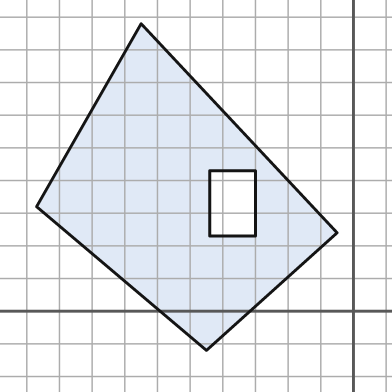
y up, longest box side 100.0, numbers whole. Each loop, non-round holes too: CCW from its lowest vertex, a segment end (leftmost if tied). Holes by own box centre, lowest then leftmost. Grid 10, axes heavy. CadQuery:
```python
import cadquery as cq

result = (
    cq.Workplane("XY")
    .moveTo(-45.0, -12.0)
    .lineTo(-5.0, 24.0)
    .lineTo(-65.0, 88.0)
    .lineTo(-97.0, 32.0)
    .close()
    .moveTo(-44.0, 23.0)
    .lineTo(-30.0, 23.0)
    .lineTo(-30.0, 43.0)
    .lineTo(-44.0, 43.0)
    .close()
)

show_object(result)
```